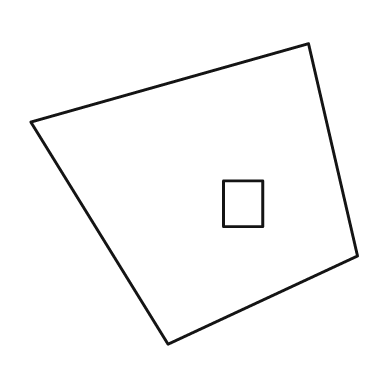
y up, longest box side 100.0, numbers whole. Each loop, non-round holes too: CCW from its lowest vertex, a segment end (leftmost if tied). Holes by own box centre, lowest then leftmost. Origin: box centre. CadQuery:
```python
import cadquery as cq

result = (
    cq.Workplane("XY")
    .moveTo(-8.0, -46.0)
    .lineTo(50.0, -19.0)
    .lineTo(35.0, 46.0)
    .lineTo(-50.0, 22.0)
    .close()
    .moveTo(9.0, -10.0)
    .lineTo(21.0, -10.0)
    .lineTo(21.0, 4.0)
    .lineTo(9.0, 4.0)
    .close()
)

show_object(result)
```